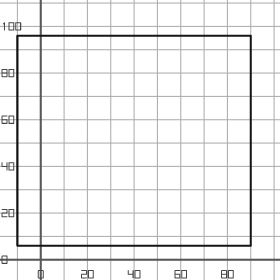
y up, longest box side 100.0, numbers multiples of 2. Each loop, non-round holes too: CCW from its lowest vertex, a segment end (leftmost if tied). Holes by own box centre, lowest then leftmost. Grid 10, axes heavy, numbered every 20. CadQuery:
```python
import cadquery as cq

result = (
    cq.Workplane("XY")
    .moveTo(-10.0, 6.0)
    .lineTo(90.0, 6.0)
    .lineTo(90.0, 96.0)
    .lineTo(-10.0, 96.0)
    .close()
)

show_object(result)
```